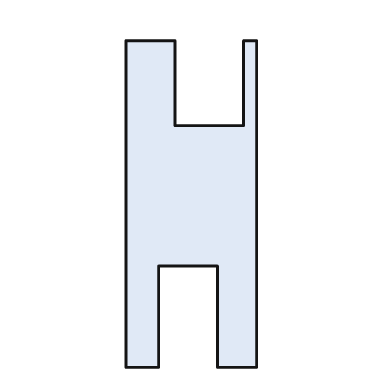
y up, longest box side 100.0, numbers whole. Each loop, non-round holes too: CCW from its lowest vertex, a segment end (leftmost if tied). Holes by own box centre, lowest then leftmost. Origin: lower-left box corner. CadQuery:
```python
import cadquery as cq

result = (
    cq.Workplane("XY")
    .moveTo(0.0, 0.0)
    .lineTo(10.0, 0.0)
    .lineTo(10.0, 31.0)
    .lineTo(28.0, 31.0)
    .lineTo(28.0, 0.0)
    .lineTo(40.0, 0.0)
    .lineTo(40.0, 100.0)
    .lineTo(36.0, 100.0)
    .lineTo(36.0, 74.0)
    .lineTo(15.0, 74.0)
    .lineTo(15.0, 100.0)
    .lineTo(0.0, 100.0)
    .close()
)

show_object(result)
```